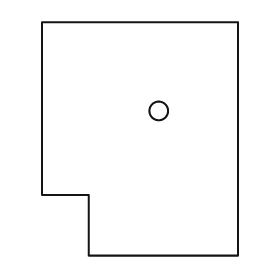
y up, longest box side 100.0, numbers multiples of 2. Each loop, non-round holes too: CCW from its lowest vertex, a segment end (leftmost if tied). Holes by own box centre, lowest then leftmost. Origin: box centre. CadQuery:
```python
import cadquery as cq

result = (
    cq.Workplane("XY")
    .moveTo(-22.0, -50.0)
    .lineTo(42.0, -50.0)
    .lineTo(42.0, 50.0)
    .lineTo(-42.0, 50.0)
    .lineTo(-42.0, -24.0)
    .lineTo(-22.0, -24.0)
    .close()
    .moveTo(8.0, 12.0)
    .circle(4.0)
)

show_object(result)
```